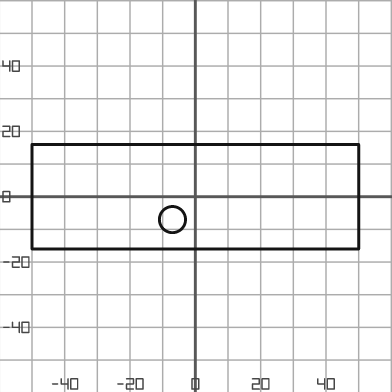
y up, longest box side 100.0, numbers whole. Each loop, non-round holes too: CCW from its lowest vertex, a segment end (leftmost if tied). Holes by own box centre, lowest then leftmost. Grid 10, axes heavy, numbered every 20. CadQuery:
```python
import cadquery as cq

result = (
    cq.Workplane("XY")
    .moveTo(-50.0, -16.0)
    .lineTo(50.0, -16.0)
    .lineTo(50.0, 16.0)
    .lineTo(-50.0, 16.0)
    .close()
    .moveTo(-7.0, -7.0)
    .circle(4.0)
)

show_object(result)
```